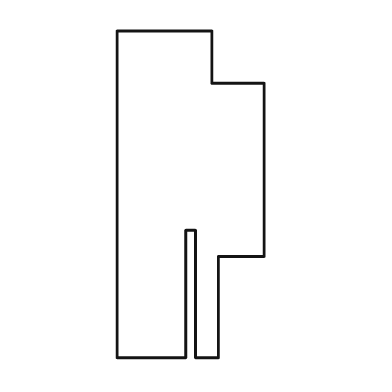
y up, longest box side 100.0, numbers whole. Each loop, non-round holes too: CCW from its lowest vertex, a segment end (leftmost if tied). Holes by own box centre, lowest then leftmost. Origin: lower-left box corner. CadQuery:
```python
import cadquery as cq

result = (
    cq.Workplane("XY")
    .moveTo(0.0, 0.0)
    .lineTo(21.0, 0.0)
    .lineTo(21.0, 39.0)
    .lineTo(24.0, 39.0)
    .lineTo(24.0, 0.0)
    .lineTo(31.0, 0.0)
    .lineTo(31.0, 31.0)
    .lineTo(45.0, 31.0)
    .lineTo(45.0, 84.0)
    .lineTo(29.0, 84.0)
    .lineTo(29.0, 100.0)
    .lineTo(0.0, 100.0)
    .close()
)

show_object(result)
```